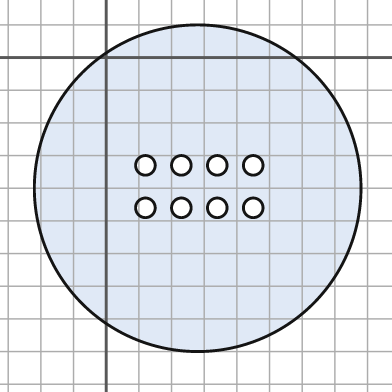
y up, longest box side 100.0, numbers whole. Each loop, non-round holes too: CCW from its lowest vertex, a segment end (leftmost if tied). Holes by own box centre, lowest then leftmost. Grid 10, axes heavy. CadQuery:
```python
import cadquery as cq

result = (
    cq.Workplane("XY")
    .moveTo(28.0, -40.0)
    .circle(50.0)
    .moveTo(12.0, -46.0)
    .circle(3.0)
    .moveTo(23.0, -46.0)
    .circle(3.0)
    .moveTo(34.0, -46.0)
    .circle(3.0)
    .moveTo(45.0, -46.0)
    .circle(3.0)
    .moveTo(12.0, -33.0)
    .circle(3.0)
    .moveTo(23.0, -33.0)
    .circle(3.0)
    .moveTo(34.0, -33.0)
    .circle(3.0)
    .moveTo(45.0, -33.0)
    .circle(3.0)
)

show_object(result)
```